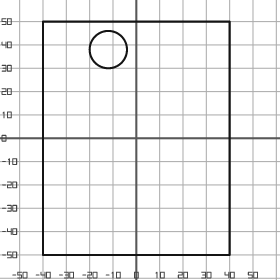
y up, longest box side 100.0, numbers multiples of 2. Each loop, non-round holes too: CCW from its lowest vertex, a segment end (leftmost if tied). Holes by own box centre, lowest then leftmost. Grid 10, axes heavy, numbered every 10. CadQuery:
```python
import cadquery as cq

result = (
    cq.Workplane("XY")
    .moveTo(-40.0, -50.0)
    .lineTo(40.0, -50.0)
    .lineTo(40.0, 50.0)
    .lineTo(-40.0, 50.0)
    .close()
    .moveTo(-12.0, 38.0)
    .circle(8.0)
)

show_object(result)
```